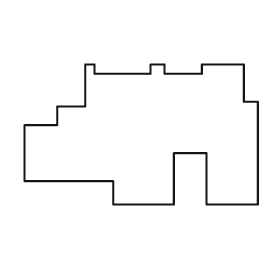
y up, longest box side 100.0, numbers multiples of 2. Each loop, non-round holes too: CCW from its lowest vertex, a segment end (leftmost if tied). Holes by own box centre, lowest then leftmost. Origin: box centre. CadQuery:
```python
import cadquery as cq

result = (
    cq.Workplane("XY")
    .moveTo(-12.0, -30.0)
    .lineTo(14.0, -30.0)
    .lineTo(14.0, -8.0)
    .lineTo(28.0, -8.0)
    .lineTo(28.0, -30.0)
    .lineTo(50.0, -30.0)
    .lineTo(50.0, 14.0)
    .lineTo(44.0, 14.0)
    .lineTo(44.0, 30.0)
    .lineTo(26.0, 30.0)
    .lineTo(26.0, 26.0)
    .lineTo(10.0, 26.0)
    .lineTo(10.0, 30.0)
    .lineTo(4.0, 30.0)
    .lineTo(4.0, 26.0)
    .lineTo(-20.0, 26.0)
    .lineTo(-20.0, 30.0)
    .lineTo(-24.0, 30.0)
    .lineTo(-24.0, 12.0)
    .lineTo(-36.0, 12.0)
    .lineTo(-36.0, 4.0)
    .lineTo(-50.0, 4.0)
    .lineTo(-50.0, -20.0)
    .lineTo(-12.0, -20.0)
    .close()
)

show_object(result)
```